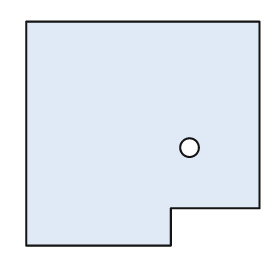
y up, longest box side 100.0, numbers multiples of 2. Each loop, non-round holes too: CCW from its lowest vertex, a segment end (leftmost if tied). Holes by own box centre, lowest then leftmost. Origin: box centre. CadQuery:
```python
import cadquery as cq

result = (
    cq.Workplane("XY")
    .moveTo(-50.0, -48.0)
    .lineTo(12.0, -48.0)
    .lineTo(12.0, -32.0)
    .lineTo(50.0, -32.0)
    .lineTo(50.0, 48.0)
    .lineTo(-50.0, 48.0)
    .close()
    .moveTo(20.0, -6.0)
    .circle(4.0)
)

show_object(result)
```